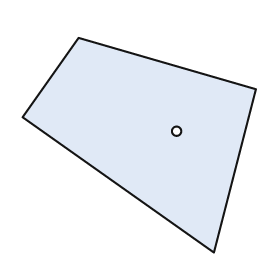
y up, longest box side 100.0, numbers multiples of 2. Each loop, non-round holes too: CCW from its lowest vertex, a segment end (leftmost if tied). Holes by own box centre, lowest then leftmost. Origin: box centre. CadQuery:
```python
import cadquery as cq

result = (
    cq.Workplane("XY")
    .moveTo(32.0, -46.0)
    .lineTo(50.0, 24.0)
    .lineTo(-26.0, 46.0)
    .lineTo(-50.0, 12.0)
    .close()
    .moveTo(16.0, 6.0)
    .circle(2.0)
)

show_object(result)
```